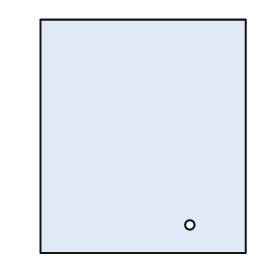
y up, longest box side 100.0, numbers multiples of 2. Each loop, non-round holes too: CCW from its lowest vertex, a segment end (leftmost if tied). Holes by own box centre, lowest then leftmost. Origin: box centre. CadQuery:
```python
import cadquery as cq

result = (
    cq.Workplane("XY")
    .moveTo(-44.0, -50.0)
    .lineTo(44.0, -50.0)
    .lineTo(44.0, 50.0)
    .lineTo(-44.0, 50.0)
    .close()
    .moveTo(20.0, -38.0)
    .circle(2.0)
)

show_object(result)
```